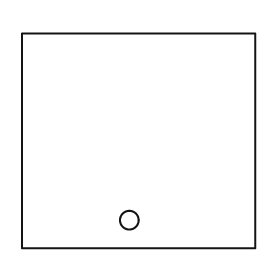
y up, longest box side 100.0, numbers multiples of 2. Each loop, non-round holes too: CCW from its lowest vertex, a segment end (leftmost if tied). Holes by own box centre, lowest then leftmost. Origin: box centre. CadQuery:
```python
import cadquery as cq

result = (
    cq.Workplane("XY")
    .moveTo(-50.0, -46.0)
    .lineTo(50.0, -46.0)
    .lineTo(50.0, 46.0)
    .lineTo(-50.0, 46.0)
    .close()
    .moveTo(-4.0, -34.0)
    .circle(4.0)
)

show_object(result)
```